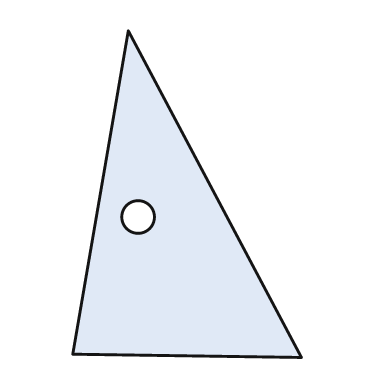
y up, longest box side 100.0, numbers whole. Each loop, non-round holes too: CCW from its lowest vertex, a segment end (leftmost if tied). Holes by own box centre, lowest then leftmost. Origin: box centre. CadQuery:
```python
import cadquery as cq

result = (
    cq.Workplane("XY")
    .moveTo(35.0, -50.0)
    .lineTo(-18.0, 50.0)
    .lineTo(-35.0, -49.0)
    .close()
    .moveTo(-15.0, -7.0)
    .circle(5.0)
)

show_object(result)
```